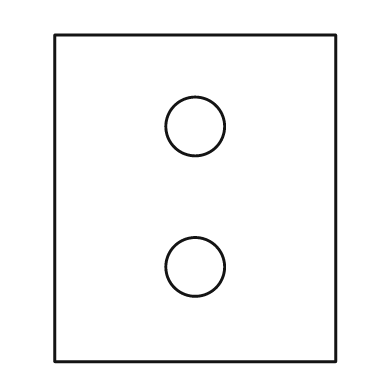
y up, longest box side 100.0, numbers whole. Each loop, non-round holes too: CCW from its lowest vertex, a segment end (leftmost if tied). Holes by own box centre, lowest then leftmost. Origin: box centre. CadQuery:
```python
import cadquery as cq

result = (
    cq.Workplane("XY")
    .moveTo(-43.0, -50.0)
    .lineTo(43.0, -50.0)
    .lineTo(43.0, 50.0)
    .lineTo(-43.0, 50.0)
    .close()
    .moveTo(0.0, -21.0)
    .circle(9.0)
    .moveTo(0.0, 22.0)
    .circle(9.0)
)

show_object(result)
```